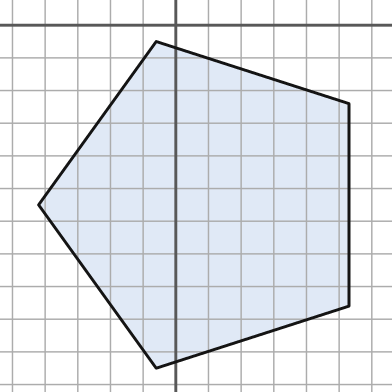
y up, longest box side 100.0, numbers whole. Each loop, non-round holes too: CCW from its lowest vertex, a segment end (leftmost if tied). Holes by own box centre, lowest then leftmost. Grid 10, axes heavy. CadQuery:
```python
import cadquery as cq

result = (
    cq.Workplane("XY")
    .moveTo(-6.0, -105.0)
    .lineTo(53.0, -86.0)
    .lineTo(53.0, -24.0)
    .lineTo(-6.0, -5.0)
    .lineTo(-42.0, -55.0)
    .close()
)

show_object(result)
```